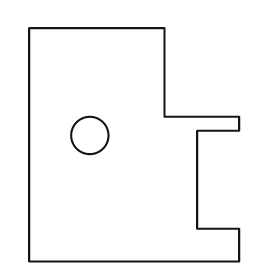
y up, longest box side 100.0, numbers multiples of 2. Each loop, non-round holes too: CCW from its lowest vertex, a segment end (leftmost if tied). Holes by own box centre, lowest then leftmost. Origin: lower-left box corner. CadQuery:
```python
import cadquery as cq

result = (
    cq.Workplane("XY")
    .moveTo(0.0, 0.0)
    .lineTo(90.0, 0.0)
    .lineTo(90.0, 14.0)
    .lineTo(72.0, 14.0)
    .lineTo(72.0, 56.0)
    .lineTo(90.0, 56.0)
    .lineTo(90.0, 62.0)
    .lineTo(58.0, 62.0)
    .lineTo(58.0, 100.0)
    .lineTo(0.0, 100.0)
    .close()
    .moveTo(26.0, 54.0)
    .circle(8.0)
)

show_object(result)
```